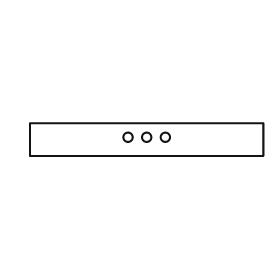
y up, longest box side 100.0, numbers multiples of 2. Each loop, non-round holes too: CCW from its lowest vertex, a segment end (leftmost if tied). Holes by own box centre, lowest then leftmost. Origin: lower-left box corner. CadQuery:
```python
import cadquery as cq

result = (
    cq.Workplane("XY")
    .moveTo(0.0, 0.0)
    .lineTo(100.0, 0.0)
    .lineTo(100.0, 14.0)
    .lineTo(0.0, 14.0)
    .close()
    .moveTo(42.0, 8.0)
    .circle(2.0)
    .moveTo(50.0, 8.0)
    .circle(2.0)
    .moveTo(58.0, 8.0)
    .circle(2.0)
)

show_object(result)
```